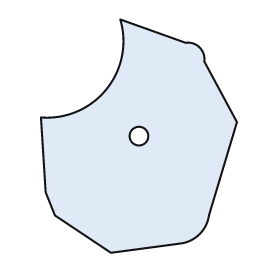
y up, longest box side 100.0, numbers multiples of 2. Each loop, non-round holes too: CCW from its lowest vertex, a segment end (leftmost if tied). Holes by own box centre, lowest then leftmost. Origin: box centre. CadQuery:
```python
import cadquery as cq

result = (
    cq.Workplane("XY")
    .moveTo(-12.0, -50.0)
    .lineTo(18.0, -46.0)
    .threePointArc((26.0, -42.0), (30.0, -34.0))
    .lineTo(42.0, 6.0)
    .lineTo(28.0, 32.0)
    .threePointArc((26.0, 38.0), (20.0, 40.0))
    .lineTo(-8.0, 50.0)
    .threePointArc((-14.0, 20.0), (-42.0, 8.0))
    .lineTo(-40.0, -24.0)
    .lineTo(-36.0, -34.0)
    .close()
    .moveTo(0.0, 0.0)
    .circle(4.0)
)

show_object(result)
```